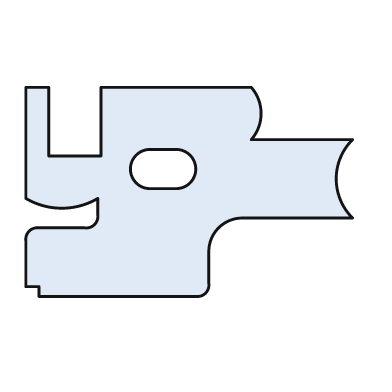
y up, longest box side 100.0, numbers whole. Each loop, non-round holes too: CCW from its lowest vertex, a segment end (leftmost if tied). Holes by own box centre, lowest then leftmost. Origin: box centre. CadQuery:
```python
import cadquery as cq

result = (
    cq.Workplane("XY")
    .moveTo(-46.0, -32.0)
    .lineTo(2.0, -32.0)
    .threePointArc((5.0, -31.0), (6.0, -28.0))
    .lineTo(6.0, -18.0)
    .threePointArc((9.0, -11.0), (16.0, -8.0))
    .lineTo(50.0, -8.0)
    .threePointArc((45.0, 4.0), (50.0, 16.0))
    .lineTo(19.0, 16.0)
    .threePointArc((22.0, 24.0), (19.0, 32.0))
    .lineTo(-27.0, 32.0)
    .lineTo(-27.0, 11.0)
    .lineTo(-43.0, 11.0)
    .lineTo(-43.0, 32.0)
    .lineTo(-50.0, 32.0)
    .lineTo(-50.0, -2.0)
    .threePointArc((-39.0, -5.0), (-28.0, -2.0))
    .lineTo(-28.0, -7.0)
    .threePointArc((-29.0, -10.0), (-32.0, -11.0))
    .lineTo(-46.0, -11.0)
    .threePointArc((-49.0, -12.0), (-50.0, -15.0))
    .lineTo(-50.0, -29.0)
    .lineTo(-46.0, -29.0)
    .close()
    .moveTo(-12.0, 1.0)
    .lineTo(-4.0, 1.0)
    .threePointArc((2.0, 7.0), (-4.0, 13.0))
    .lineTo(-12.0, 13.0)
    .threePointArc((-18.0, 7.0), (-12.0, 1.0))
    .close()
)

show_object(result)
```